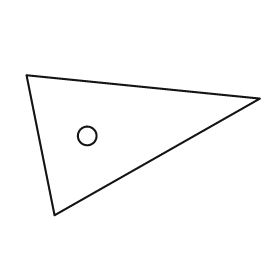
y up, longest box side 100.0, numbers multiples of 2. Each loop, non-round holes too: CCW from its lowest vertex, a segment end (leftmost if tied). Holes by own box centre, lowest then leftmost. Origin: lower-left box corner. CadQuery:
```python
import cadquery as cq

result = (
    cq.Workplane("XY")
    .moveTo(12.0, 0.0)
    .lineTo(100.0, 50.0)
    .lineTo(0.0, 60.0)
    .close()
    .moveTo(26.0, 34.0)
    .circle(4.0)
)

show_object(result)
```